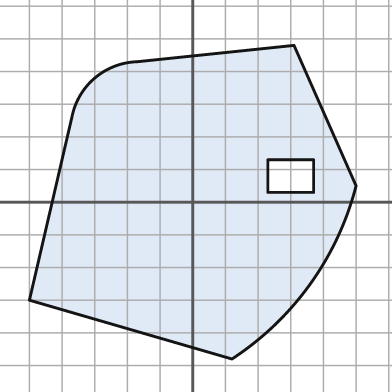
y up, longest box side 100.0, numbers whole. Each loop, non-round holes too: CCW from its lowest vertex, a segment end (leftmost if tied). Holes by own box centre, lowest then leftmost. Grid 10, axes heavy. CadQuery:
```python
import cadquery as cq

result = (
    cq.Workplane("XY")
    .moveTo(12.0, -48.0)
    .threePointArc((36.0, -25.0), (50.0, 5.0))
    .lineTo(31.0, 48.0)
    .lineTo(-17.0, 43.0)
    .threePointArc((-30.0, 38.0), (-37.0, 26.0))
    .lineTo(-50.0, -30.0)
    .close()
    .moveTo(23.0, 3.0)
    .lineTo(37.0, 3.0)
    .lineTo(37.0, 13.0)
    .lineTo(23.0, 13.0)
    .close()
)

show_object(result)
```